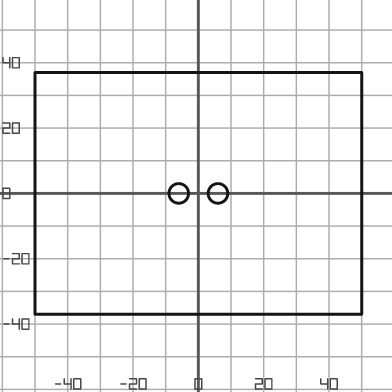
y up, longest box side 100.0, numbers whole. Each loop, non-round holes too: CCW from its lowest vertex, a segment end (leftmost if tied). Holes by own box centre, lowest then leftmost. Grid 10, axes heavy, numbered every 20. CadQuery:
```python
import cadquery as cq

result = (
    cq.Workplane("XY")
    .moveTo(-50.0, -37.0)
    .lineTo(50.0, -37.0)
    .lineTo(50.0, 37.0)
    .lineTo(-50.0, 37.0)
    .close()
    .moveTo(-6.0, 0.0)
    .circle(3.0)
    .moveTo(6.0, 0.0)
    .circle(3.0)
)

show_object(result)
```